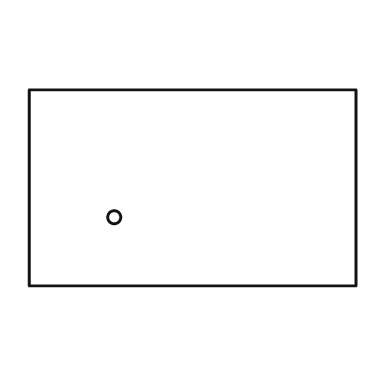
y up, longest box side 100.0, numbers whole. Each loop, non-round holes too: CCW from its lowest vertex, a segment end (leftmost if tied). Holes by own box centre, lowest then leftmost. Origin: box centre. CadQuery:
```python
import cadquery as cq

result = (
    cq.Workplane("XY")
    .moveTo(-50.0, -30.0)
    .lineTo(50.0, -30.0)
    .lineTo(50.0, 30.0)
    .lineTo(-50.0, 30.0)
    .close()
    .moveTo(-24.0, -9.0)
    .circle(2.0)
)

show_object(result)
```